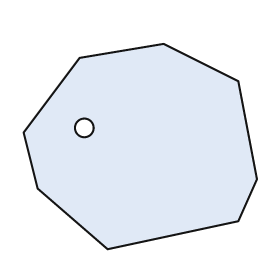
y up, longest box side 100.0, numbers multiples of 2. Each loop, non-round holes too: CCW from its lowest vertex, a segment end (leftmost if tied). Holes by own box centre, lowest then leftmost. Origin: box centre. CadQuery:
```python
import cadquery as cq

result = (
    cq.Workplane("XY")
    .moveTo(-14.0, -44.0)
    .lineTo(42.0, -32.0)
    .lineTo(50.0, -14.0)
    .lineTo(42.0, 28.0)
    .lineTo(10.0, 44.0)
    .lineTo(-26.0, 38.0)
    .lineTo(-50.0, 6.0)
    .lineTo(-44.0, -18.0)
    .close()
    .moveTo(-24.0, 8.0)
    .circle(4.0)
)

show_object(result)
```